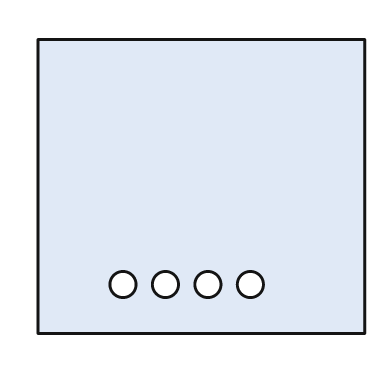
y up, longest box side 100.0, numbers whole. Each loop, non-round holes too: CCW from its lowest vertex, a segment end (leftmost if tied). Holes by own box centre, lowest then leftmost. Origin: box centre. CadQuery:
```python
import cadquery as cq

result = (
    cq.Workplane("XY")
    .moveTo(-50.0, -45.0)
    .lineTo(50.0, -45.0)
    .lineTo(50.0, 45.0)
    .lineTo(-50.0, 45.0)
    .close()
    .moveTo(-24.0, -30.0)
    .circle(4.0)
    .moveTo(-11.0, -30.0)
    .circle(4.0)
    .moveTo(2.0, -30.0)
    .circle(4.0)
    .moveTo(15.0, -30.0)
    .circle(4.0)
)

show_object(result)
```